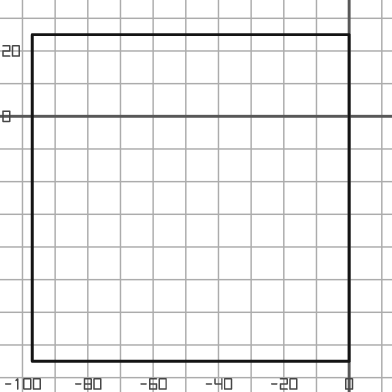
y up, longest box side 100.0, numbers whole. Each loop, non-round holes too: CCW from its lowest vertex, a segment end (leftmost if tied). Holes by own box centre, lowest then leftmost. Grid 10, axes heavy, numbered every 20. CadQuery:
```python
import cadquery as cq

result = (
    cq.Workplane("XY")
    .moveTo(-97.0, -75.0)
    .lineTo(0.0, -75.0)
    .lineTo(0.0, 25.0)
    .lineTo(-97.0, 25.0)
    .close()
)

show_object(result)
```